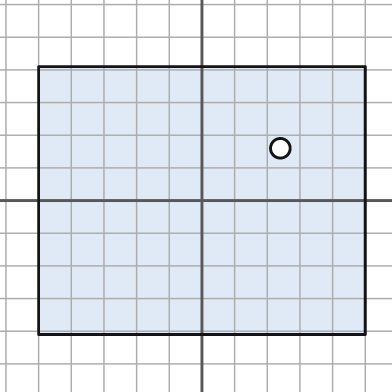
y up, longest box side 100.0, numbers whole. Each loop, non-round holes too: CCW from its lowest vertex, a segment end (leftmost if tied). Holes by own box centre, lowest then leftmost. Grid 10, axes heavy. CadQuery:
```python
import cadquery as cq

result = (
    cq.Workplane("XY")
    .moveTo(-50.0, -41.0)
    .lineTo(50.0, -41.0)
    .lineTo(50.0, 41.0)
    .lineTo(-50.0, 41.0)
    .close()
    .moveTo(24.0, 16.0)
    .circle(3.0)
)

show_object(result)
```